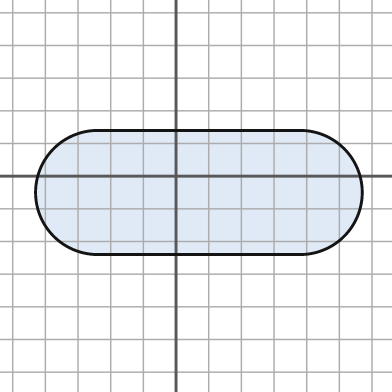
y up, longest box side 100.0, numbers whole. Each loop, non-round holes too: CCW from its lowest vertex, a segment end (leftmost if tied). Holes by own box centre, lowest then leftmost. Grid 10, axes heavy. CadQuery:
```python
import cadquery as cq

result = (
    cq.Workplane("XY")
    .moveTo(-24.0, -24.0)
    .lineTo(38.0, -24.0)
    .threePointArc((57.0, -5.0), (38.0, 14.0))
    .lineTo(-24.0, 14.0)
    .threePointArc((-43.0, -5.0), (-24.0, -24.0))
    .close()
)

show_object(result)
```